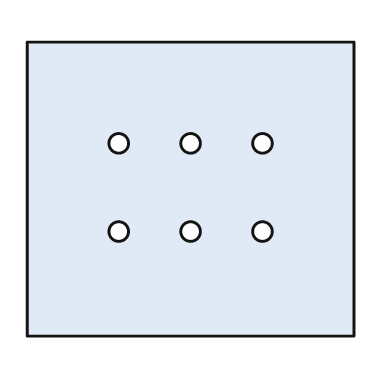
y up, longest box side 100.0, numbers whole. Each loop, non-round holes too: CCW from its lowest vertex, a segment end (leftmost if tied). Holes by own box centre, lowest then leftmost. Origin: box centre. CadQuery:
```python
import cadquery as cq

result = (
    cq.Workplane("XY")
    .moveTo(-50.0, -45.0)
    .lineTo(50.0, -45.0)
    .lineTo(50.0, 45.0)
    .lineTo(-50.0, 45.0)
    .close()
    .moveTo(-22.0, -13.0)
    .circle(3.0)
    .moveTo(0.0, -13.0)
    .circle(3.0)
    .moveTo(22.0, -13.0)
    .circle(3.0)
    .moveTo(-22.0, 14.0)
    .circle(3.0)
    .moveTo(0.0, 14.0)
    .circle(3.0)
    .moveTo(22.0, 14.0)
    .circle(3.0)
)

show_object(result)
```